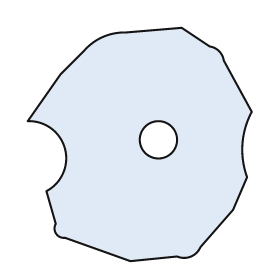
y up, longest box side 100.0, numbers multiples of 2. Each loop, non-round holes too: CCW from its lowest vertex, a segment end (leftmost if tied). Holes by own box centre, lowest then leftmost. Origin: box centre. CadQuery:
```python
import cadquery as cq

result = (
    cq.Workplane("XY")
    .moveTo(-4.0, -50.0)
    .lineTo(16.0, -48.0)
    .threePointArc((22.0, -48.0), (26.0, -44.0))
    .lineTo(40.0, -28.0)
    .lineTo(46.0, -14.0)
    .threePointArc((44.0, 0.0), (48.0, 14.0))
    .lineTo(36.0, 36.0)
    .threePointArc((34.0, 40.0), (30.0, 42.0))
    .lineTo(18.0, 50.0)
    .lineTo(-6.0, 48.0)
    .threePointArc((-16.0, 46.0), (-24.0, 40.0))
    .lineTo(-34.0, 30.0)
    .lineTo(-48.0, 10.0)
    .threePointArc((-32.0, -2.0), (-40.0, -20.0))
    .lineTo(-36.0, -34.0)
    .threePointArc((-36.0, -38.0), (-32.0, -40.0))
    .close()
    .moveTo(8.0, 2.0)
    .circle(8.0)
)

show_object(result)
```